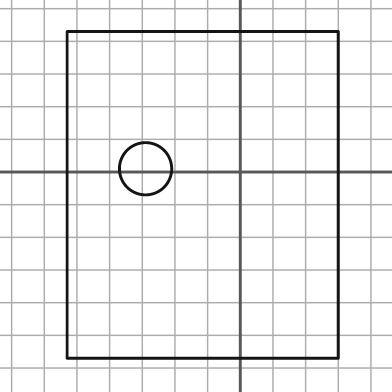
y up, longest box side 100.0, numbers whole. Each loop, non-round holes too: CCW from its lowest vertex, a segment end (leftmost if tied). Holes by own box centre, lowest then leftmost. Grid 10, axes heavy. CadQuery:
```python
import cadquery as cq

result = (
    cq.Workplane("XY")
    .moveTo(-53.0, -57.0)
    .lineTo(30.0, -57.0)
    .lineTo(30.0, 43.0)
    .lineTo(-53.0, 43.0)
    .close()
    .moveTo(-29.0, 1.0)
    .circle(8.0)
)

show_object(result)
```